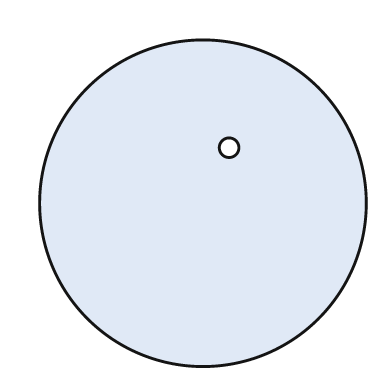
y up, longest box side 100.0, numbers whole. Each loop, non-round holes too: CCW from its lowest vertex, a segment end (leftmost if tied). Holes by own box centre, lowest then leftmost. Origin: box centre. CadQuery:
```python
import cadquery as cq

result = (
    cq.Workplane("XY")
    .moveTo(0.0, 0.0)
    .circle(50.0)
    .moveTo(8.0, 17.0)
    .circle(3.0)
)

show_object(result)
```